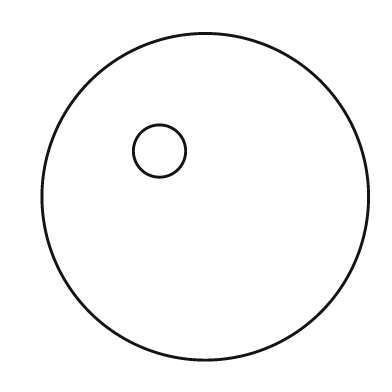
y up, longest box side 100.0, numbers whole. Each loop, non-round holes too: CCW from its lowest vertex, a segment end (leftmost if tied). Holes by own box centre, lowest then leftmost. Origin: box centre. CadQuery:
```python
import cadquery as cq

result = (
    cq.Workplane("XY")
    .moveTo(0.0, 0.0)
    .circle(50.0)
    .moveTo(-14.0, 14.0)
    .circle(8.0)
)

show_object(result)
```